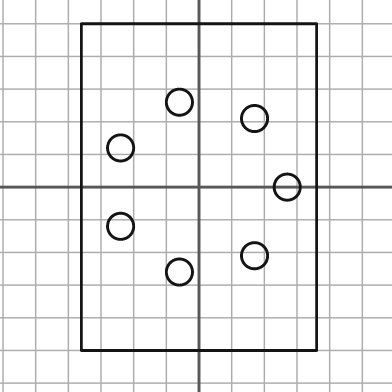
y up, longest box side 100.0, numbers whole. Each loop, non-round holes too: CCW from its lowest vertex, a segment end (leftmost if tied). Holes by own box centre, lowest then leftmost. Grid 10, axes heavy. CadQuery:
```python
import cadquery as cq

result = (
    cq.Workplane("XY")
    .moveTo(-36.0, -50.0)
    .lineTo(36.0, -50.0)
    .lineTo(36.0, 50.0)
    .lineTo(-36.0, 50.0)
    .close()
    .moveTo(-6.0, -26.0)
    .circle(4.0)
    .moveTo(17.0, -21.0)
    .circle(4.0)
    .moveTo(-24.0, -12.0)
    .circle(4.0)
    .moveTo(27.0, 0.0)
    .circle(4.0)
    .moveTo(-24.0, 12.0)
    .circle(4.0)
    .moveTo(17.0, 21.0)
    .circle(4.0)
    .moveTo(-6.0, 26.0)
    .circle(4.0)
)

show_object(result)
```